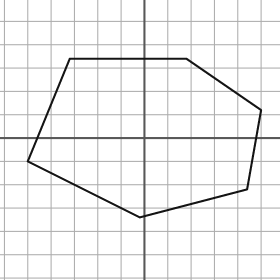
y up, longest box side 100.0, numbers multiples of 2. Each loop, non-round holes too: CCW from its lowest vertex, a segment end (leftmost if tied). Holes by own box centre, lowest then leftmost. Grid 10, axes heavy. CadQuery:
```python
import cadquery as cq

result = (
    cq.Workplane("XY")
    .moveTo(-2.0, -34.0)
    .lineTo(44.0, -22.0)
    .lineTo(50.0, 12.0)
    .lineTo(18.0, 34.0)
    .lineTo(-32.0, 34.0)
    .lineTo(-50.0, -10.0)
    .close()
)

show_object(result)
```